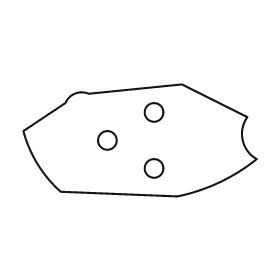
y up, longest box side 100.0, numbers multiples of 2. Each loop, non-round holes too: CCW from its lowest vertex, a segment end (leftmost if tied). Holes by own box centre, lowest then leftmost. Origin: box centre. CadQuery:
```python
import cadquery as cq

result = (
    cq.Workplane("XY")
    .moveTo(16.0, -24.0)
    .threePointArc((34.0, -18.0), (50.0, -8.0))
    .threePointArc((44.0, 0.0), (46.0, 10.0))
    .lineTo(18.0, 24.0)
    .lineTo(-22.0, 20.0)
    .threePointArc((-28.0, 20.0), (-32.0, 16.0))
    .lineTo(-50.0, 4.0)
    .threePointArc((-44.0, -10.0), (-34.0, -22.0))
    .close()
    .moveTo(6.0, -12.0)
    .circle(4.0)
    .moveTo(-14.0, 0.0)
    .circle(4.0)
    .moveTo(6.0, 12.0)
    .circle(4.0)
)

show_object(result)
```